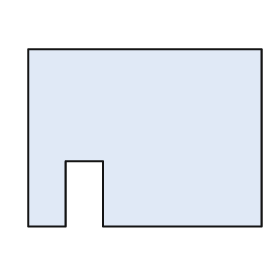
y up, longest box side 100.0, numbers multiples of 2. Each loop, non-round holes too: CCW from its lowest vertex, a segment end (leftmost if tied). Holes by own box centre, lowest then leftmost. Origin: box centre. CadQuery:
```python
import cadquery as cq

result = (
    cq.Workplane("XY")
    .moveTo(-50.0, -38.0)
    .lineTo(-34.0, -38.0)
    .lineTo(-34.0, -10.0)
    .lineTo(-18.0, -10.0)
    .lineTo(-18.0, -38.0)
    .lineTo(50.0, -38.0)
    .lineTo(50.0, 38.0)
    .lineTo(-50.0, 38.0)
    .close()
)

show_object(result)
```